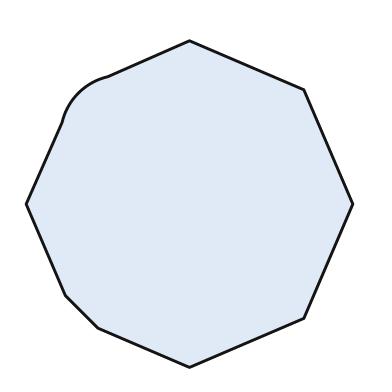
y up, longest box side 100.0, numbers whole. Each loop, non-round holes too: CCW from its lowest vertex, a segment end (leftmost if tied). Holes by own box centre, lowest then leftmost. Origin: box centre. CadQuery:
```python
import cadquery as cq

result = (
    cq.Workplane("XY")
    .moveTo(0.0, -50.0)
    .lineTo(35.0, -35.0)
    .lineTo(50.0, 0.0)
    .lineTo(35.0, 35.0)
    .lineTo(0.0, 50.0)
    .lineTo(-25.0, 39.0)
    .threePointArc((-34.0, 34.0), (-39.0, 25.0))
    .lineTo(-50.0, 0.0)
    .lineTo(-38.0, -28.0)
    .lineTo(-28.0, -38.0)
    .close()
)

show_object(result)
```